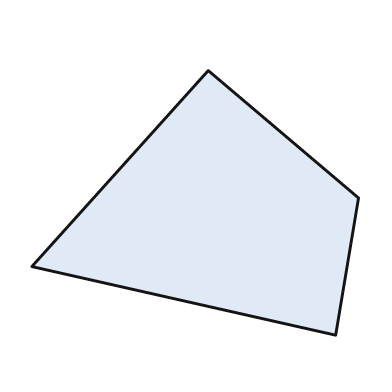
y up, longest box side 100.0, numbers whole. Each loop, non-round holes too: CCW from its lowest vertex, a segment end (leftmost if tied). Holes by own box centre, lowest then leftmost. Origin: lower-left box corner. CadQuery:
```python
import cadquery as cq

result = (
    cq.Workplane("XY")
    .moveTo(93.0, 0.0)
    .lineTo(100.0, 42.0)
    .lineTo(54.0, 81.0)
    .lineTo(0.0, 21.0)
    .close()
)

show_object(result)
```